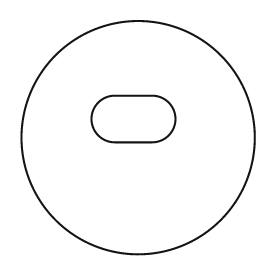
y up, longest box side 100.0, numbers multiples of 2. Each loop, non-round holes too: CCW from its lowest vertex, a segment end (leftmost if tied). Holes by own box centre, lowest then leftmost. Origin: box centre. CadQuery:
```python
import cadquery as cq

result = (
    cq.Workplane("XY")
    .moveTo(0.0, 0.0)
    .circle(50.0)
    .moveTo(-10.0, -2.0)
    .lineTo(6.0, -2.0)
    .threePointArc((16.0, 8.0), (6.0, 18.0))
    .lineTo(-10.0, 18.0)
    .threePointArc((-20.0, 8.0), (-10.0, -2.0))
    .close()
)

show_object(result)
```